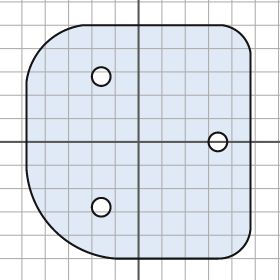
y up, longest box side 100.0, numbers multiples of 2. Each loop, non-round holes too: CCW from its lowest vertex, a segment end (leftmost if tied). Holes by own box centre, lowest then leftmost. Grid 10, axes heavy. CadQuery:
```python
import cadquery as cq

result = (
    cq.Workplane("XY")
    .moveTo(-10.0, -50.0)
    .lineTo(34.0, -50.0)
    .threePointArc((44.0, -46.0), (48.0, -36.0))
    .lineTo(48.0, 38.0)
    .threePointArc((44.0, 46.0), (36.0, 50.0))
    .lineTo(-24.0, 50.0)
    .threePointArc((-40.0, 42.0), (-48.0, 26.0))
    .lineTo(-48.0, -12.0)
    .threePointArc((-36.0, -38.0), (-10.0, -50.0))
    .close()
    .moveTo(-16.0, -28.0)
    .circle(4.0)
    .moveTo(34.0, 0.0)
    .circle(4.0)
    .moveTo(-16.0, 28.0)
    .circle(4.0)
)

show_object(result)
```